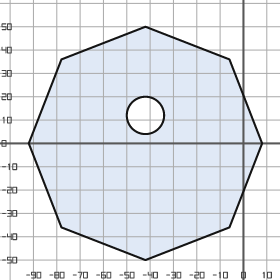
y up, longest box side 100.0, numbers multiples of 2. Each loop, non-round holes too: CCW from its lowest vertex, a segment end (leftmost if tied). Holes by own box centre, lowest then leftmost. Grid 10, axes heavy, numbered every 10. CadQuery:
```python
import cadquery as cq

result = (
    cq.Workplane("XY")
    .moveTo(-42.0, -50.0)
    .lineTo(-6.0, -36.0)
    .lineTo(8.0, 0.0)
    .lineTo(-6.0, 36.0)
    .lineTo(-42.0, 50.0)
    .lineTo(-78.0, 36.0)
    .lineTo(-92.0, 0.0)
    .lineTo(-78.0, -36.0)
    .close()
    .moveTo(-42.0, 12.0)
    .circle(8.0)
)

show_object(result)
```